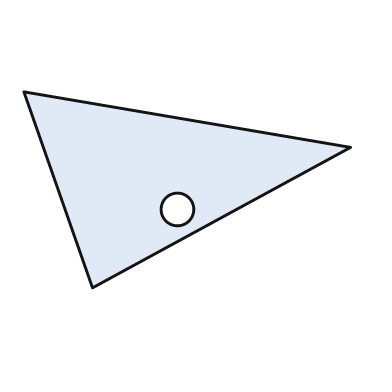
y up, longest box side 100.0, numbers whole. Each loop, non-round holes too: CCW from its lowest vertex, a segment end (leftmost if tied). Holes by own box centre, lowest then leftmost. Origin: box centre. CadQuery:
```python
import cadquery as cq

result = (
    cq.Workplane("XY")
    .moveTo(-29.0, -30.0)
    .lineTo(50.0, 13.0)
    .lineTo(-50.0, 30.0)
    .close()
    .moveTo(-3.0, -6.0)
    .circle(5.0)
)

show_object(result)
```